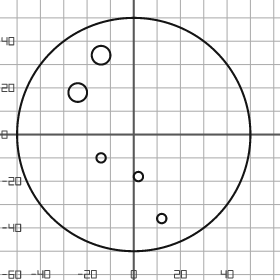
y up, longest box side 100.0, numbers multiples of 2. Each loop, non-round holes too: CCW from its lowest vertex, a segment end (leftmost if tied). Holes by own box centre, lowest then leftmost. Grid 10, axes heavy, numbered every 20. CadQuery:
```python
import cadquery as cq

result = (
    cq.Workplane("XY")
    .moveTo(0.0, 0.0)
    .circle(50.0)
    .moveTo(12.0, -36.0)
    .circle(2.0)
    .moveTo(2.0, -18.0)
    .circle(2.0)
    .moveTo(-14.0, -10.0)
    .circle(2.0)
    .moveTo(-24.0, 18.0)
    .circle(4.0)
    .moveTo(-14.0, 34.0)
    .circle(4.0)
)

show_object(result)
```